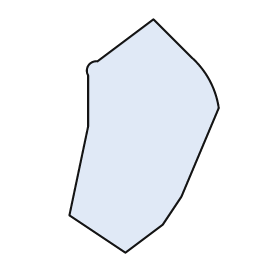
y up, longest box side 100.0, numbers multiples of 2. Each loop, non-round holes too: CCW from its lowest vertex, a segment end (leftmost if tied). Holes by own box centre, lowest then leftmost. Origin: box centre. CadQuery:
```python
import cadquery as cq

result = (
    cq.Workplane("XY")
    .moveTo(-8.0, -50.0)
    .lineTo(8.0, -38.0)
    .lineTo(16.0, -26.0)
    .lineTo(32.0, 12.0)
    .threePointArc((28.0, 24.0), (20.0, 34.0))
    .lineTo(4.0, 50.0)
    .lineTo(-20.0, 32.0)
    .threePointArc((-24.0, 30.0), (-24.0, 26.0))
    .lineTo(-24.0, 4.0)
    .lineTo(-32.0, -34.0)
    .close()
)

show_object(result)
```